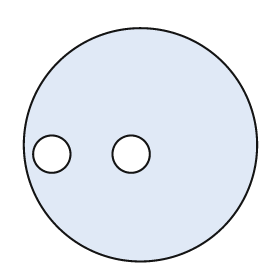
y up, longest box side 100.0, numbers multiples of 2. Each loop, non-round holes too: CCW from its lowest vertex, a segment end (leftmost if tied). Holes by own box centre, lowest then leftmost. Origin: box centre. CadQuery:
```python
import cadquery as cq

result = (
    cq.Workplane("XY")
    .moveTo(0.0, 0.0)
    .circle(50.0)
    .moveTo(-38.0, -4.0)
    .circle(8.0)
    .moveTo(-4.0, -4.0)
    .circle(8.0)
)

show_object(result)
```